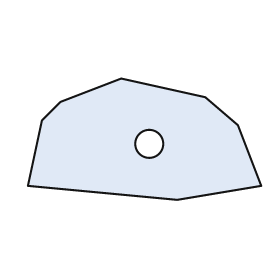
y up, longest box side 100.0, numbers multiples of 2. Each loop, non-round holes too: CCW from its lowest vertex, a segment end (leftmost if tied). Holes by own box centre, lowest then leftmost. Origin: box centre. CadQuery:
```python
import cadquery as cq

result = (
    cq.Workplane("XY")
    .moveTo(14.0, -26.0)
    .lineTo(50.0, -20.0)
    .lineTo(40.0, 6.0)
    .lineTo(26.0, 18.0)
    .lineTo(-10.0, 26.0)
    .lineTo(-36.0, 16.0)
    .lineTo(-44.0, 8.0)
    .lineTo(-50.0, -20.0)
    .close()
    .moveTo(2.0, -2.0)
    .circle(6.0)
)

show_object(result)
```